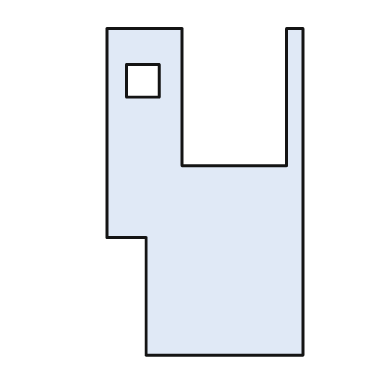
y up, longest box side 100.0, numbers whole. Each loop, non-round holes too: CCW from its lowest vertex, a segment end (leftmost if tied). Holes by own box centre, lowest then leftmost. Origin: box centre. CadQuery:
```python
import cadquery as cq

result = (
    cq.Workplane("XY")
    .moveTo(-18.0, -50.0)
    .lineTo(30.0, -50.0)
    .lineTo(30.0, 50.0)
    .lineTo(25.0, 50.0)
    .lineTo(25.0, 8.0)
    .lineTo(-7.0, 8.0)
    .lineTo(-7.0, 50.0)
    .lineTo(-30.0, 50.0)
    .lineTo(-30.0, -14.0)
    .lineTo(-18.0, -14.0)
    .close()
    .moveTo(-24.0, 29.0)
    .lineTo(-14.0, 29.0)
    .lineTo(-14.0, 39.0)
    .lineTo(-24.0, 39.0)
    .close()
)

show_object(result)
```